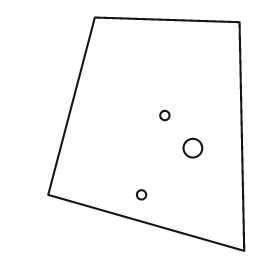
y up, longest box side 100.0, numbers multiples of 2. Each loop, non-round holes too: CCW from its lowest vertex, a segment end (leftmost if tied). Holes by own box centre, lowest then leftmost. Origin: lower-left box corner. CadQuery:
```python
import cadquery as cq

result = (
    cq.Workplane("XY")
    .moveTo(84.0, 0.0)
    .lineTo(82.0, 98.0)
    .lineTo(20.0, 100.0)
    .lineTo(0.0, 24.0)
    .close()
    .moveTo(40.0, 24.0)
    .circle(2.0)
    .moveTo(62.0, 44.0)
    .circle(4.0)
    .moveTo(50.0, 58.0)
    .circle(2.0)
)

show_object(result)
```